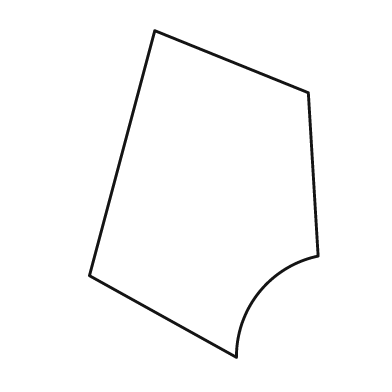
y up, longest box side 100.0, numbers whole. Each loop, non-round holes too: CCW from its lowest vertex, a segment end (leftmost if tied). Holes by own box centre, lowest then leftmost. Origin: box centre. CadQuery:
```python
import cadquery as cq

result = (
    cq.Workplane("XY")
    .moveTo(10.0, -50.0)
    .threePointArc((17.0, -30.0), (35.0, -19.0))
    .lineTo(32.0, 31.0)
    .lineTo(-15.0, 50.0)
    .lineTo(-35.0, -25.0)
    .close()
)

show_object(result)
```